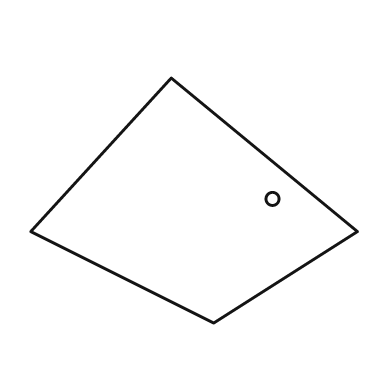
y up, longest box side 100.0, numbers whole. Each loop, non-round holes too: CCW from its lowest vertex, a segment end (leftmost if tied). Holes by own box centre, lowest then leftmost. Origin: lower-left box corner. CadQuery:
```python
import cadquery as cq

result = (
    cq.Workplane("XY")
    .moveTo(56.0, 0.0)
    .lineTo(100.0, 28.0)
    .lineTo(43.0, 75.0)
    .lineTo(0.0, 28.0)
    .close()
    .moveTo(74.0, 38.0)
    .circle(2.0)
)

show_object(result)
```